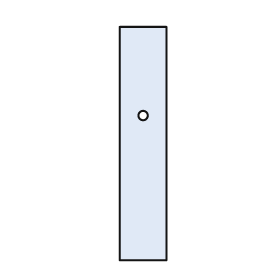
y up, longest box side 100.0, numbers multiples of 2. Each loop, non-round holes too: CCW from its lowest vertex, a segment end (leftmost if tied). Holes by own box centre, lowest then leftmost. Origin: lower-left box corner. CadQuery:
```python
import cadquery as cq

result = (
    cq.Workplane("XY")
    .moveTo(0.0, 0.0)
    .lineTo(20.0, 0.0)
    .lineTo(20.0, 100.0)
    .lineTo(0.0, 100.0)
    .close()
    .moveTo(10.0, 62.0)
    .circle(2.0)
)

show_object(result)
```